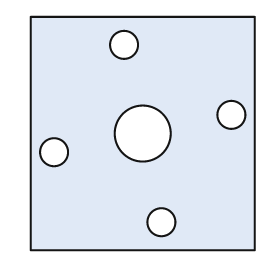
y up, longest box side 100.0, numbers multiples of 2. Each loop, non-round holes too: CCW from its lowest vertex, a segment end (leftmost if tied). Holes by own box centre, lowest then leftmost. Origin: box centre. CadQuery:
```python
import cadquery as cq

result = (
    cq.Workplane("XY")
    .moveTo(-48.0, -50.0)
    .lineTo(48.0, -50.0)
    .lineTo(48.0, 50.0)
    .lineTo(-48.0, 50.0)
    .close()
    .moveTo(8.0, -38.0)
    .circle(6.0)
    .moveTo(-38.0, -8.0)
    .circle(6.0)
    .moveTo(0.0, 0.0)
    .circle(12.0)
    .moveTo(38.0, 8.0)
    .circle(6.0)
    .moveTo(-8.0, 38.0)
    .circle(6.0)
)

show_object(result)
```